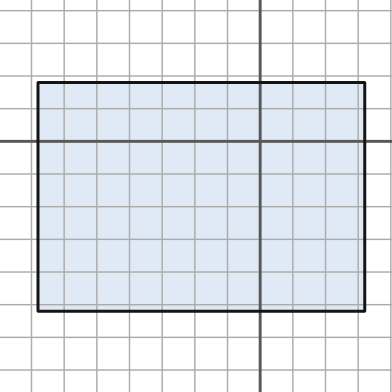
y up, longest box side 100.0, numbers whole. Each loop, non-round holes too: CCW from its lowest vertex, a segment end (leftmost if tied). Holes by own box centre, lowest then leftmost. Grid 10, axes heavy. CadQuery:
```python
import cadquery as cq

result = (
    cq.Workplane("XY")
    .moveTo(-68.0, -52.0)
    .lineTo(32.0, -52.0)
    .lineTo(32.0, 18.0)
    .lineTo(-68.0, 18.0)
    .close()
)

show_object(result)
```